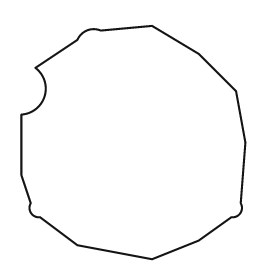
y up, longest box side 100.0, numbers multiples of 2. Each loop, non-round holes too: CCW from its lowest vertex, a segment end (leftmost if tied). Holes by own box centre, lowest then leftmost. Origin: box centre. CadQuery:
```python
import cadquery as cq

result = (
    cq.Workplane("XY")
    .moveTo(8.0, -50.0)
    .lineTo(28.0, -42.0)
    .lineTo(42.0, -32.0)
    .threePointArc((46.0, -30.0), (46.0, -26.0))
    .lineTo(48.0, 0.0)
    .lineTo(44.0, 22.0)
    .lineTo(28.0, 38.0)
    .lineTo(8.0, 50.0)
    .lineTo(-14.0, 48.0)
    .threePointArc((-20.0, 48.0), (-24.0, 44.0))
    .lineTo(-42.0, 32.0)
    .threePointArc((-38.0, 20.0), (-48.0, 12.0))
    .lineTo(-48.0, -14.0)
    .lineTo(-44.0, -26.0)
    .threePointArc((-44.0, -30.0), (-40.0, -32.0))
    .lineTo(-24.0, -44.0)
    .close()
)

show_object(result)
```